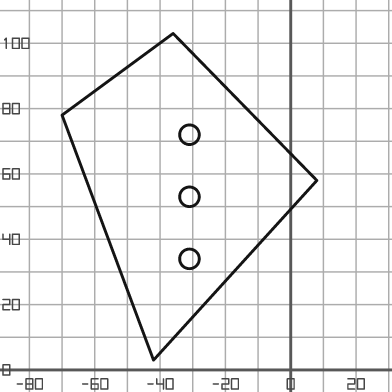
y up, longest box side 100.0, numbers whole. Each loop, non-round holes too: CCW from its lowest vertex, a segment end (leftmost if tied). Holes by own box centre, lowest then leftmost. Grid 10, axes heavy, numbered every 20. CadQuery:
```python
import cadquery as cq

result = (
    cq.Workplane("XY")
    .moveTo(-42.0, 3.0)
    .lineTo(8.0, 58.0)
    .lineTo(-36.0, 103.0)
    .lineTo(-70.0, 78.0)
    .close()
    .moveTo(-31.0, 34.0)
    .circle(3.0)
    .moveTo(-31.0, 53.0)
    .circle(3.0)
    .moveTo(-31.0, 72.0)
    .circle(3.0)
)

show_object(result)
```